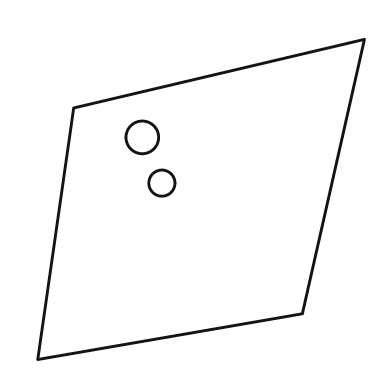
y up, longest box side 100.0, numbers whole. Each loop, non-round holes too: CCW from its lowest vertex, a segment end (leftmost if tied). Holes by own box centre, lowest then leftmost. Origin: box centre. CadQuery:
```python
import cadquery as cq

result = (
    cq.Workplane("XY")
    .moveTo(-50.0, -49.0)
    .lineTo(31.0, -35.0)
    .lineTo(50.0, 49.0)
    .lineTo(-39.0, 28.0)
    .close()
    .moveTo(-12.0, 5.0)
    .circle(4.0)
    .moveTo(-18.0, 19.0)
    .circle(5.0)
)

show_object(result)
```